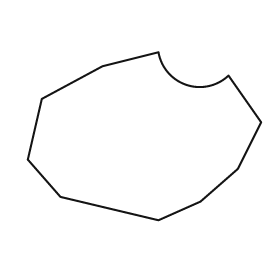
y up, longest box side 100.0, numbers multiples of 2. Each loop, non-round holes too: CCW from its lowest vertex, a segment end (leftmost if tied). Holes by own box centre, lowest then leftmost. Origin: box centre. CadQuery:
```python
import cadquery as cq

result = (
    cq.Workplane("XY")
    .moveTo(6.0, -36.0)
    .lineTo(24.0, -28.0)
    .lineTo(40.0, -14.0)
    .lineTo(50.0, 6.0)
    .lineTo(36.0, 26.0)
    .threePointArc((18.0, 22.0), (6.0, 36.0))
    .lineTo(-18.0, 30.0)
    .lineTo(-44.0, 16.0)
    .lineTo(-50.0, -10.0)
    .lineTo(-36.0, -26.0)
    .close()
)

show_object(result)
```